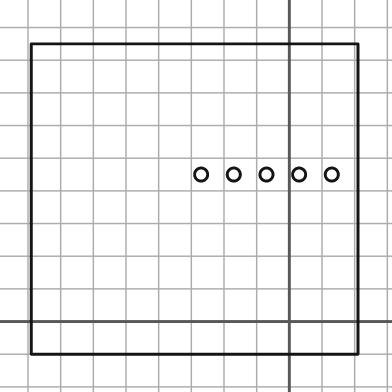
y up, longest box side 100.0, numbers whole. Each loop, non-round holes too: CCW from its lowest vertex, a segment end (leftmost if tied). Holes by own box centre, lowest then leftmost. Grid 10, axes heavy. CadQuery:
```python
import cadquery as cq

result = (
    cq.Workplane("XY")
    .moveTo(-79.0, -10.0)
    .lineTo(21.0, -10.0)
    .lineTo(21.0, 85.0)
    .lineTo(-79.0, 85.0)
    .close()
    .moveTo(-27.0, 45.0)
    .circle(2.0)
    .moveTo(-17.0, 45.0)
    .circle(2.0)
    .moveTo(-7.0, 45.0)
    .circle(2.0)
    .moveTo(3.0, 45.0)
    .circle(2.0)
    .moveTo(13.0, 45.0)
    .circle(2.0)
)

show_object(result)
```